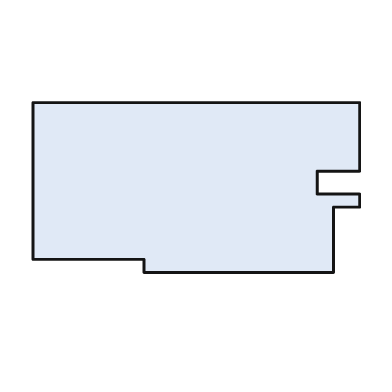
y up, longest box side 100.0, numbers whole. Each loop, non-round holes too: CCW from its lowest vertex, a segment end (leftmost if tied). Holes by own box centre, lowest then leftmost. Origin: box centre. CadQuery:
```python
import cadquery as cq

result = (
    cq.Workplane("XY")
    .moveTo(-16.0, -26.0)
    .lineTo(42.0, -26.0)
    .lineTo(42.0, -6.0)
    .lineTo(50.0, -6.0)
    .lineTo(50.0, -2.0)
    .lineTo(37.0, -2.0)
    .lineTo(37.0, 5.0)
    .lineTo(50.0, 5.0)
    .lineTo(50.0, 26.0)
    .lineTo(-50.0, 26.0)
    .lineTo(-50.0, -22.0)
    .lineTo(-16.0, -22.0)
    .close()
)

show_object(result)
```